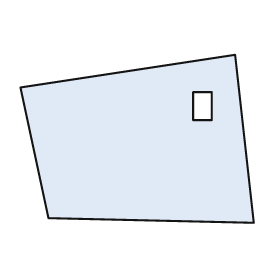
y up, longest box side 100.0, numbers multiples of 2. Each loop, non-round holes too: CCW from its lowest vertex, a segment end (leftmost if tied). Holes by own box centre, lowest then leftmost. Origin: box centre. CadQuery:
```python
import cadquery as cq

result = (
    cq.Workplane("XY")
    .moveTo(50.0, -36.0)
    .lineTo(42.0, 36.0)
    .lineTo(-50.0, 22.0)
    .lineTo(-38.0, -34.0)
    .close()
    .moveTo(24.0, 8.0)
    .lineTo(32.0, 8.0)
    .lineTo(32.0, 20.0)
    .lineTo(24.0, 20.0)
    .close()
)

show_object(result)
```